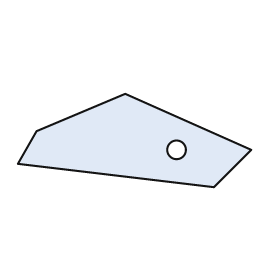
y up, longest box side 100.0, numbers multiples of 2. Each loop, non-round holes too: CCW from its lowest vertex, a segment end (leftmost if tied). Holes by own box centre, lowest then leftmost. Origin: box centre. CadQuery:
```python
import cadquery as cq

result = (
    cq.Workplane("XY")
    .moveTo(34.0, -20.0)
    .lineTo(50.0, -4.0)
    .lineTo(-4.0, 20.0)
    .lineTo(-42.0, 4.0)
    .lineTo(-50.0, -10.0)
    .close()
    .moveTo(18.0, -4.0)
    .circle(4.0)
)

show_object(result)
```